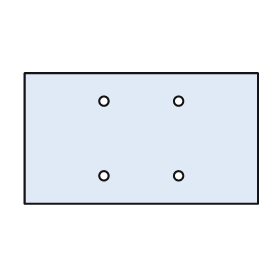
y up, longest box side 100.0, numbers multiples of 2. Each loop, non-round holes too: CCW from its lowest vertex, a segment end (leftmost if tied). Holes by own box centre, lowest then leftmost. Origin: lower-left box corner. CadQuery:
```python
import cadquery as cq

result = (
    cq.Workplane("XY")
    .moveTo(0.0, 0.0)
    .lineTo(100.0, 0.0)
    .lineTo(100.0, 56.0)
    .lineTo(0.0, 56.0)
    .close()
    .moveTo(34.0, 12.0)
    .circle(2.0)
    .moveTo(66.0, 12.0)
    .circle(2.0)
    .moveTo(34.0, 44.0)
    .circle(2.0)
    .moveTo(66.0, 44.0)
    .circle(2.0)
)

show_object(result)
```